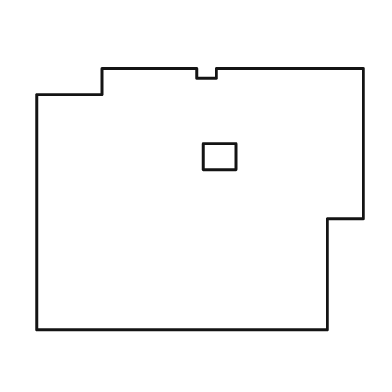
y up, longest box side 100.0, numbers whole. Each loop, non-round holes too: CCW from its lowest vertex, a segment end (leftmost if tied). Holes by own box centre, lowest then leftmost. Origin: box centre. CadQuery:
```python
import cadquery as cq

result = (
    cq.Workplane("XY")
    .moveTo(-50.0, -40.0)
    .lineTo(39.0, -40.0)
    .lineTo(39.0, -6.0)
    .lineTo(50.0, -6.0)
    .lineTo(50.0, 40.0)
    .lineTo(5.0, 40.0)
    .lineTo(5.0, 37.0)
    .lineTo(-1.0, 37.0)
    .lineTo(-1.0, 40.0)
    .lineTo(-30.0, 40.0)
    .lineTo(-30.0, 32.0)
    .lineTo(-50.0, 32.0)
    .close()
    .moveTo(1.0, 9.0)
    .lineTo(11.0, 9.0)
    .lineTo(11.0, 17.0)
    .lineTo(1.0, 17.0)
    .close()
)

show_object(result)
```